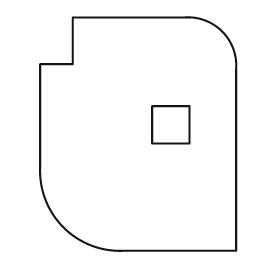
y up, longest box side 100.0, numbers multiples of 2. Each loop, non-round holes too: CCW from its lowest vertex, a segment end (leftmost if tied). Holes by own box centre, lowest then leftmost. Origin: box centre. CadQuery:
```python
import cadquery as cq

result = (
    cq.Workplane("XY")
    .moveTo(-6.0, -50.0)
    .lineTo(42.0, -50.0)
    .lineTo(42.0, 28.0)
    .threePointArc((36.0, 44.0), (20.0, 50.0))
    .lineTo(-28.0, 50.0)
    .lineTo(-28.0, 30.0)
    .lineTo(-42.0, 30.0)
    .lineTo(-42.0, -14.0)
    .threePointArc((-32.0, -40.0), (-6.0, -50.0))
    .close()
    .moveTo(6.0, -4.0)
    .lineTo(22.0, -4.0)
    .lineTo(22.0, 12.0)
    .lineTo(6.0, 12.0)
    .close()
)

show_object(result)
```